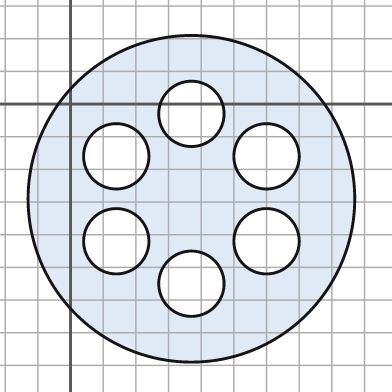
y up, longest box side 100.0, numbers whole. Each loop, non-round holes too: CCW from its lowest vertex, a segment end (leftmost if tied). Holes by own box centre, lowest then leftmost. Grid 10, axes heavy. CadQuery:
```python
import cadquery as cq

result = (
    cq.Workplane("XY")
    .moveTo(37.0, -29.0)
    .circle(50.0)
    .moveTo(37.0, -55.0)
    .circle(10.0)
    .moveTo(14.0, -42.0)
    .circle(10.0)
    .moveTo(60.0, -42.0)
    .circle(10.0)
    .moveTo(14.0, -16.0)
    .circle(10.0)
    .moveTo(60.0, -16.0)
    .circle(10.0)
    .moveTo(37.0, -3.0)
    .circle(10.0)
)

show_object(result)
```